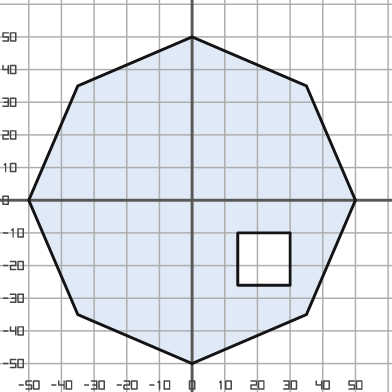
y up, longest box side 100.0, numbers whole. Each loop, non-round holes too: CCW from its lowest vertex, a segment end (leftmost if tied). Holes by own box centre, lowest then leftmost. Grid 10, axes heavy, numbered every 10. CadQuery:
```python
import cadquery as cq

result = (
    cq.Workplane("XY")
    .moveTo(0.0, -50.0)
    .lineTo(35.0, -35.0)
    .lineTo(50.0, 0.0)
    .lineTo(35.0, 35.0)
    .lineTo(0.0, 50.0)
    .lineTo(-35.0, 35.0)
    .lineTo(-50.0, 0.0)
    .lineTo(-35.0, -35.0)
    .close()
    .moveTo(14.0, -26.0)
    .lineTo(30.0, -26.0)
    .lineTo(30.0, -10.0)
    .lineTo(14.0, -10.0)
    .close()
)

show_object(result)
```